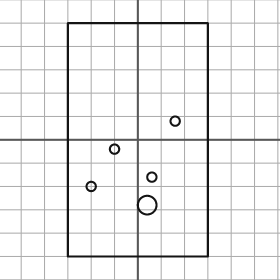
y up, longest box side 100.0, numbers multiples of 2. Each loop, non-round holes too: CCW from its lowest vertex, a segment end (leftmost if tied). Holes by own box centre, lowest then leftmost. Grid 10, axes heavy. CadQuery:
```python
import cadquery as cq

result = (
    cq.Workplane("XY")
    .moveTo(-30.0, -50.0)
    .lineTo(30.0, -50.0)
    .lineTo(30.0, 50.0)
    .lineTo(-30.0, 50.0)
    .close()
    .moveTo(4.0, -28.0)
    .circle(4.0)
    .moveTo(-20.0, -20.0)
    .circle(2.0)
    .moveTo(6.0, -16.0)
    .circle(2.0)
    .moveTo(-10.0, -4.0)
    .circle(2.0)
    .moveTo(16.0, 8.0)
    .circle(2.0)
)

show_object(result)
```